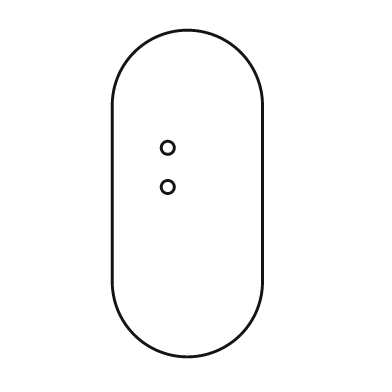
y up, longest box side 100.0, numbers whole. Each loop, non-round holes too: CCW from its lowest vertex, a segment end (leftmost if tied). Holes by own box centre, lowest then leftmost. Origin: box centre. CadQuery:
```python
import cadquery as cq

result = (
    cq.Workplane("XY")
    .moveTo(-23.0, -27.0)
    .threePointArc((0.0, -50.0), (23.0, -27.0))
    .lineTo(23.0, 27.0)
    .threePointArc((0.0, 50.0), (-23.0, 27.0))
    .close()
    .moveTo(-6.0, 2.0)
    .circle(2.0)
    .moveTo(-6.0, 14.0)
    .circle(2.0)
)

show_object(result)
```